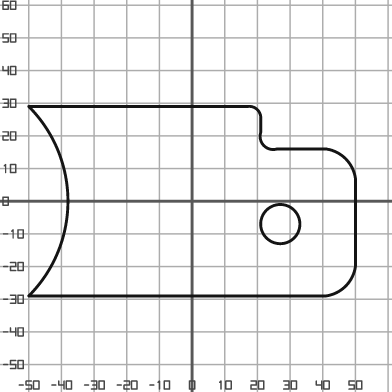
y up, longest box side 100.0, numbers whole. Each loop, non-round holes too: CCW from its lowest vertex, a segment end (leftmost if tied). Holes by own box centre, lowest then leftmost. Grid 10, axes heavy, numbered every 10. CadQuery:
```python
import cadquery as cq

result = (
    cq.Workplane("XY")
    .moveTo(-50.0, -29.0)
    .lineTo(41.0, -29.0)
    .threePointArc((47.0, -26.0), (50.0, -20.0))
    .lineTo(50.0, 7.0)
    .threePointArc((47.0, 13.0), (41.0, 16.0))
    .lineTo(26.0, 16.0)
    .threePointArc((22.0, 17.0), (21.0, 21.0))
    .lineTo(21.0, 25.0)
    .threePointArc((20.0, 28.0), (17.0, 29.0))
    .lineTo(-50.0, 29.0)
    .threePointArc((-38.0, 0.0), (-50.0, -29.0))
    .close()
    .moveTo(27.0, -7.0)
    .circle(6.0)
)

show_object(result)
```